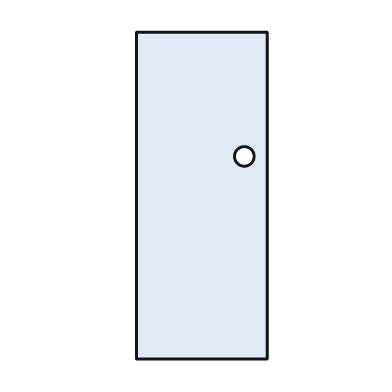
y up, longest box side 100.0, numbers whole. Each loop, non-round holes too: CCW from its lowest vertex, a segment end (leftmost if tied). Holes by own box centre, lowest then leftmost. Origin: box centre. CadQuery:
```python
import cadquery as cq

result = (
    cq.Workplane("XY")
    .moveTo(-20.0, -50.0)
    .lineTo(20.0, -50.0)
    .lineTo(20.0, 50.0)
    .lineTo(-20.0, 50.0)
    .close()
    .moveTo(13.0, 12.0)
    .circle(3.0)
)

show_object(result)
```